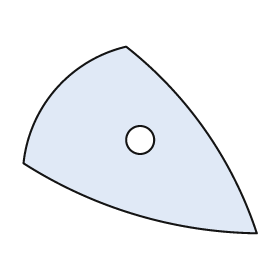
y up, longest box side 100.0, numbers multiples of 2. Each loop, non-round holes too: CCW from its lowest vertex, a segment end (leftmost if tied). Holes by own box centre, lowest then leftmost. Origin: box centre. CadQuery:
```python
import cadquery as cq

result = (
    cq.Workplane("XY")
    .moveTo(50.0, -40.0)
    .threePointArc((28.0, 4.0), (-6.0, 40.0))
    .threePointArc((-36.0, 22.0), (-50.0, -10.0))
    .threePointArc((-2.0, -32.0), (50.0, -40.0))
    .close()
    .moveTo(0.0, 0.0)
    .circle(6.0)
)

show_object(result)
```